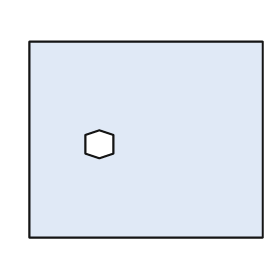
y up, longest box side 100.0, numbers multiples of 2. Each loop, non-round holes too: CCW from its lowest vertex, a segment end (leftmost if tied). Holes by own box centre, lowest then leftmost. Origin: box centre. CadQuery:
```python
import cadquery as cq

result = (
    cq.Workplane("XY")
    .moveTo(-50.0, -42.0)
    .lineTo(50.0, -42.0)
    .lineTo(50.0, 42.0)
    .lineTo(-50.0, 42.0)
    .close()
    .moveTo(-20.0, -8.0)
    .lineTo(-14.0, -6.0)
    .lineTo(-14.0, 2.0)
    .lineTo(-20.0, 4.0)
    .lineTo(-26.0, 2.0)
    .lineTo(-26.0, -6.0)
    .close()
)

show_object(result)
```